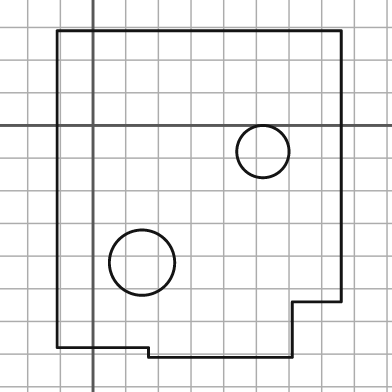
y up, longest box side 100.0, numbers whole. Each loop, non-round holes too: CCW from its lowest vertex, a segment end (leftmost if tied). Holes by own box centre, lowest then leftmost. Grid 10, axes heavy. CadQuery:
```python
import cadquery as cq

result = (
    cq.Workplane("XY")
    .moveTo(17.0, -71.0)
    .lineTo(61.0, -71.0)
    .lineTo(61.0, -54.0)
    .lineTo(76.0, -54.0)
    .lineTo(76.0, 29.0)
    .lineTo(-11.0, 29.0)
    .lineTo(-11.0, -68.0)
    .lineTo(17.0, -68.0)
    .close()
    .moveTo(15.0, -42.0)
    .circle(10.0)
    .moveTo(52.0, -8.0)
    .circle(8.0)
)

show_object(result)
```